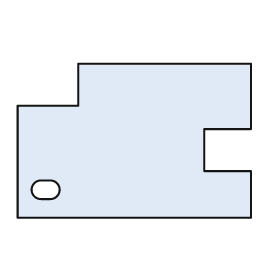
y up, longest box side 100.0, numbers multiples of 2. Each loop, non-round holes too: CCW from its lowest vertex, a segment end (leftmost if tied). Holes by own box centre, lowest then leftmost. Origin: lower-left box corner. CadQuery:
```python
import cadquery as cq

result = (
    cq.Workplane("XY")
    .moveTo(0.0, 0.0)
    .lineTo(100.0, 0.0)
    .lineTo(100.0, 20.0)
    .lineTo(80.0, 20.0)
    .lineTo(80.0, 38.0)
    .lineTo(100.0, 38.0)
    .lineTo(100.0, 66.0)
    .lineTo(26.0, 66.0)
    .lineTo(26.0, 48.0)
    .lineTo(0.0, 48.0)
    .close()
    .moveTo(10.0, 8.0)
    .lineTo(14.0, 8.0)
    .threePointArc((18.0, 12.0), (14.0, 16.0))
    .lineTo(10.0, 16.0)
    .threePointArc((6.0, 12.0), (10.0, 8.0))
    .close()
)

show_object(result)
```